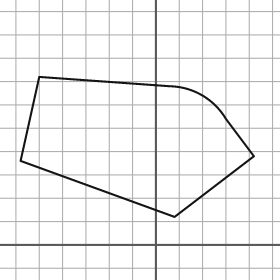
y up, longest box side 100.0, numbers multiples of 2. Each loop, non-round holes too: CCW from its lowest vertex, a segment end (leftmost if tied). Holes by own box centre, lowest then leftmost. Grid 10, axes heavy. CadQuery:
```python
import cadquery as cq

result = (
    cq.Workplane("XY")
    .moveTo(8.0, 12.0)
    .lineTo(42.0, 38.0)
    .lineTo(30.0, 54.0)
    .threePointArc((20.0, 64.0), (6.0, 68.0))
    .lineTo(-50.0, 72.0)
    .lineTo(-58.0, 36.0)
    .close()
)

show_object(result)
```